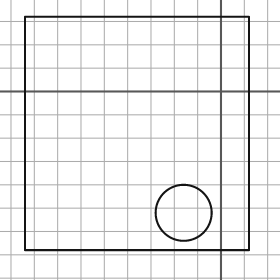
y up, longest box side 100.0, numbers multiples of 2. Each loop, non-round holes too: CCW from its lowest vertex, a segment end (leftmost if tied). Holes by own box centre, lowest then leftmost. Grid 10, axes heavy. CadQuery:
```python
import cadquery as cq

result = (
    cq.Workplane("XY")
    .moveTo(-84.0, -68.0)
    .lineTo(12.0, -68.0)
    .lineTo(12.0, 32.0)
    .lineTo(-84.0, 32.0)
    .close()
    .moveTo(-16.0, -52.0)
    .circle(12.0)
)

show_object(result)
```